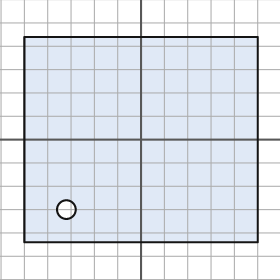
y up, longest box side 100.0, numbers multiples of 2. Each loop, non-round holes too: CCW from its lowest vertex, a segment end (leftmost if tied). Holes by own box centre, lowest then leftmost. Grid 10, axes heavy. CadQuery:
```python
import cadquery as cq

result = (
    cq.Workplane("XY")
    .moveTo(-50.0, -44.0)
    .lineTo(50.0, -44.0)
    .lineTo(50.0, 44.0)
    .lineTo(-50.0, 44.0)
    .close()
    .moveTo(-32.0, -30.0)
    .circle(4.0)
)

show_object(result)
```